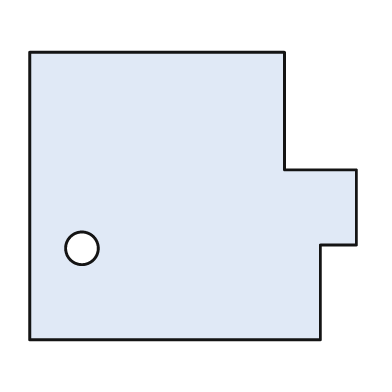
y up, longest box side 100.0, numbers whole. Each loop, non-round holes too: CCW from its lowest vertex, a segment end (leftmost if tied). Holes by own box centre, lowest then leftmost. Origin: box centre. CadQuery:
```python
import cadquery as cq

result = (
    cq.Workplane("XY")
    .moveTo(-50.0, -44.0)
    .lineTo(39.0, -44.0)
    .lineTo(39.0, -15.0)
    .lineTo(50.0, -15.0)
    .lineTo(50.0, 8.0)
    .lineTo(28.0, 8.0)
    .lineTo(28.0, 44.0)
    .lineTo(-50.0, 44.0)
    .close()
    .moveTo(-34.0, -16.0)
    .circle(5.0)
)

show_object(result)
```